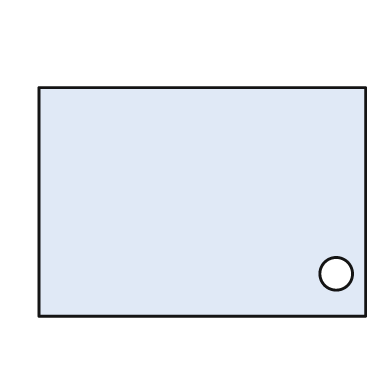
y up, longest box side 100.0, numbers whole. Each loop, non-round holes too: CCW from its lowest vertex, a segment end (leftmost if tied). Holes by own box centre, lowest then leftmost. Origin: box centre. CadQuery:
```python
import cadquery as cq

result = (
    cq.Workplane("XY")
    .moveTo(-50.0, -35.0)
    .lineTo(50.0, -35.0)
    .lineTo(50.0, 35.0)
    .lineTo(-50.0, 35.0)
    .close()
    .moveTo(41.0, -22.0)
    .circle(5.0)
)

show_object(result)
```